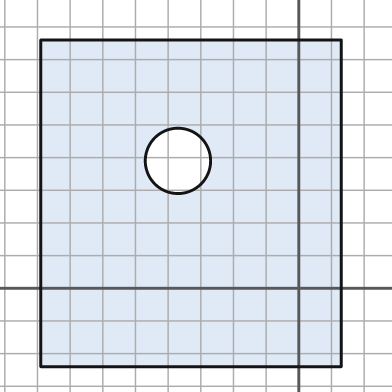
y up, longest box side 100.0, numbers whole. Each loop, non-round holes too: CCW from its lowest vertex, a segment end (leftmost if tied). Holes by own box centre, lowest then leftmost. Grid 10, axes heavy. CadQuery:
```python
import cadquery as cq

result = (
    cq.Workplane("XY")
    .moveTo(-79.0, -24.0)
    .lineTo(13.0, -24.0)
    .lineTo(13.0, 76.0)
    .lineTo(-79.0, 76.0)
    .close()
    .moveTo(-37.0, 39.0)
    .circle(10.0)
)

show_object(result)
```